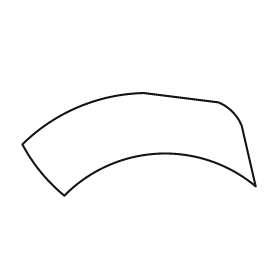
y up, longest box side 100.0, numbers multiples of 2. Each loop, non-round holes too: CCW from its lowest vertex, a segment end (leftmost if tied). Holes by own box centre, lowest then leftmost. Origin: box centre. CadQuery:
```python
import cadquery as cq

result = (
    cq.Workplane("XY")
    .moveTo(-32.0, -22.0)
    .threePointArc((8.0, -4.0), (50.0, -18.0))
    .lineTo(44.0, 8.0)
    .threePointArc((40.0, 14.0), (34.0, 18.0))
    .lineTo(2.0, 22.0)
    .threePointArc((-26.0, 16.0), (-50.0, 0.0))
    .threePointArc((-42.0, -12.0), (-32.0, -22.0))
    .close()
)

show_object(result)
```